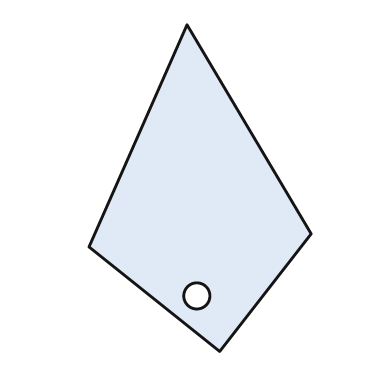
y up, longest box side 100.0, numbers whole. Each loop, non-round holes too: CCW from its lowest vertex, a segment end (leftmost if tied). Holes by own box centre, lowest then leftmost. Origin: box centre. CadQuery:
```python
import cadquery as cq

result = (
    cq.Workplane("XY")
    .moveTo(6.0, -50.0)
    .lineTo(34.0, -14.0)
    .lineTo(-4.0, 50.0)
    .lineTo(-34.0, -18.0)
    .close()
    .moveTo(-1.0, -33.0)
    .circle(4.0)
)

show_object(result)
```